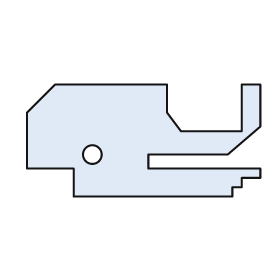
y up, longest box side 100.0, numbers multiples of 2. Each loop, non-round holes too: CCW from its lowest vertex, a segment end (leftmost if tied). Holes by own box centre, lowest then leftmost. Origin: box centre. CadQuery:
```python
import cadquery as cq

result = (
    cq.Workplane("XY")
    .moveTo(-30.0, -24.0)
    .lineTo(38.0, -24.0)
    .lineTo(38.0, -20.0)
    .lineTo(42.0, -20.0)
    .lineTo(42.0, -16.0)
    .lineTo(50.0, -16.0)
    .lineTo(50.0, -12.0)
    .lineTo(2.0, -12.0)
    .lineTo(2.0, -6.0)
    .lineTo(36.0, -6.0)
    .lineTo(50.0, 6.0)
    .lineTo(50.0, 24.0)
    .lineTo(42.0, 24.0)
    .lineTo(42.0, 4.0)
    .lineTo(16.0, 4.0)
    .lineTo(10.0, 12.0)
    .lineTo(10.0, 24.0)
    .lineTo(-38.0, 24.0)
    .lineTo(-50.0, 12.0)
    .lineTo(-50.0, -12.0)
    .lineTo(-30.0, -12.0)
    .close()
    .moveTo(-22.0, -6.0)
    .circle(4.0)
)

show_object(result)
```